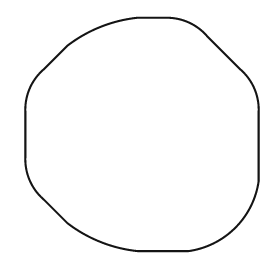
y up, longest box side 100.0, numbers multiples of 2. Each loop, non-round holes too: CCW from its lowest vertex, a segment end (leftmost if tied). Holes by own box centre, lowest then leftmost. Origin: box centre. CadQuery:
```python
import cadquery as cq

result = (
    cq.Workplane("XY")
    .moveTo(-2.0, -50.0)
    .lineTo(20.0, -50.0)
    .threePointArc((40.0, -40.0), (50.0, -20.0))
    .lineTo(50.0, 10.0)
    .threePointArc((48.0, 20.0), (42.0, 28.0))
    .lineTo(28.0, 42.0)
    .threePointArc((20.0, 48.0), (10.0, 50.0))
    .lineTo(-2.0, 50.0)
    .threePointArc((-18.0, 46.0), (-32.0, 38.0))
    .lineTo(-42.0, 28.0)
    .threePointArc((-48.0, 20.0), (-50.0, 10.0))
    .lineTo(-50.0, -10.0)
    .threePointArc((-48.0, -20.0), (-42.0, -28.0))
    .lineTo(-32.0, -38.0)
    .threePointArc((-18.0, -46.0), (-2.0, -50.0))
    .close()
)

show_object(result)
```